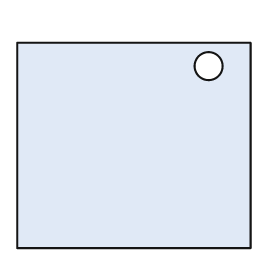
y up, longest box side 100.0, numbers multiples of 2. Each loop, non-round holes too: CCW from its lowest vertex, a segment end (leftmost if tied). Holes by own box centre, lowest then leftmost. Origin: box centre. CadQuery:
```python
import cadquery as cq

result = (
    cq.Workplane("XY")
    .moveTo(-50.0, -44.0)
    .lineTo(50.0, -44.0)
    .lineTo(50.0, 44.0)
    .lineTo(-50.0, 44.0)
    .close()
    .moveTo(32.0, 34.0)
    .circle(6.0)
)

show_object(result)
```